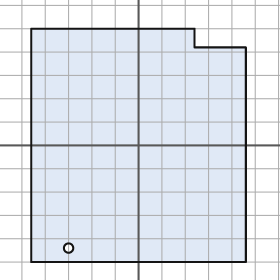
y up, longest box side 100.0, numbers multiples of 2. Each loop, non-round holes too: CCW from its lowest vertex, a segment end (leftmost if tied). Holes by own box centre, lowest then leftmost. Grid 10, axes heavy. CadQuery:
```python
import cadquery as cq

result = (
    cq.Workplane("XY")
    .moveTo(-46.0, -50.0)
    .lineTo(46.0, -50.0)
    .lineTo(46.0, 42.0)
    .lineTo(24.0, 42.0)
    .lineTo(24.0, 50.0)
    .lineTo(-46.0, 50.0)
    .close()
    .moveTo(-30.0, -44.0)
    .circle(2.0)
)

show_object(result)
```